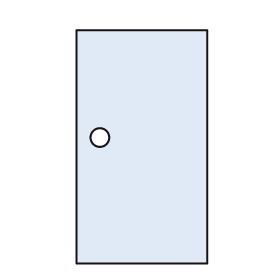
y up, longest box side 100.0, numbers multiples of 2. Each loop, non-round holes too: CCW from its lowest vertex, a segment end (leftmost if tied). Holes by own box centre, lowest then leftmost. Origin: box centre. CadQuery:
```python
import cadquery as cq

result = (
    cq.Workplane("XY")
    .moveTo(-28.0, -50.0)
    .lineTo(28.0, -50.0)
    .lineTo(28.0, 50.0)
    .lineTo(-28.0, 50.0)
    .close()
    .moveTo(-18.0, 4.0)
    .circle(4.0)
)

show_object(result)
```